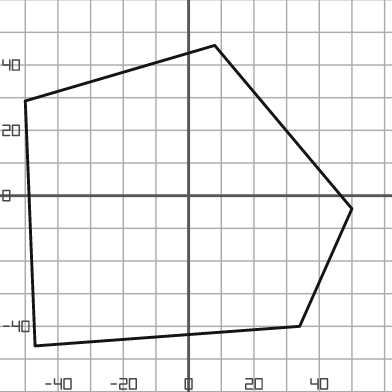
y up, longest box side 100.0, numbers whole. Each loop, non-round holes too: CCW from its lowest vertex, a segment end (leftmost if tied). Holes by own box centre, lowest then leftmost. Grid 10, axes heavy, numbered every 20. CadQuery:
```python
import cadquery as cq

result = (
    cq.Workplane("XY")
    .moveTo(-47.0, -46.0)
    .lineTo(34.0, -40.0)
    .lineTo(50.0, -4.0)
    .lineTo(8.0, 46.0)
    .lineTo(-50.0, 29.0)
    .close()
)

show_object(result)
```